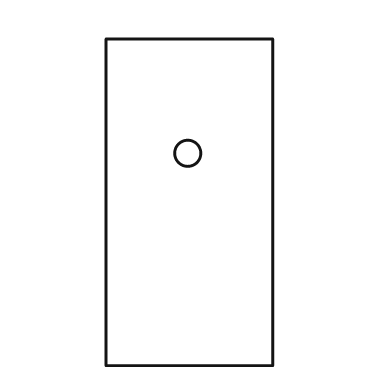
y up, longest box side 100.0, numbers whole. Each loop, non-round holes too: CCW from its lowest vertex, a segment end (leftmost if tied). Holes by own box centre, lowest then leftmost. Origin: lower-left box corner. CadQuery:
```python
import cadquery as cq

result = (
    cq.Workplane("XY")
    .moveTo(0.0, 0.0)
    .lineTo(51.0, 0.0)
    .lineTo(51.0, 100.0)
    .lineTo(0.0, 100.0)
    .close()
    .moveTo(25.0, 65.0)
    .circle(4.0)
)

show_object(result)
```